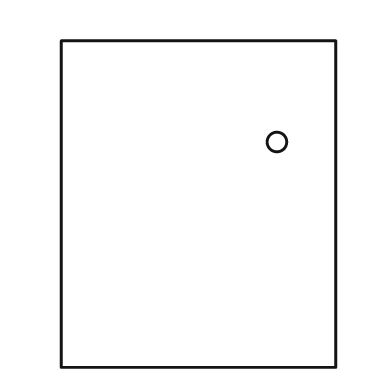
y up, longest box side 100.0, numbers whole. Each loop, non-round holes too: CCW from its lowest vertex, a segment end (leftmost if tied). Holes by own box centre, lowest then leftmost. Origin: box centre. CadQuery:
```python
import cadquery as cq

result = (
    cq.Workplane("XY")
    .moveTo(-42.0, -50.0)
    .lineTo(42.0, -50.0)
    .lineTo(42.0, 50.0)
    .lineTo(-42.0, 50.0)
    .close()
    .moveTo(24.0, 19.0)
    .circle(3.0)
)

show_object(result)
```